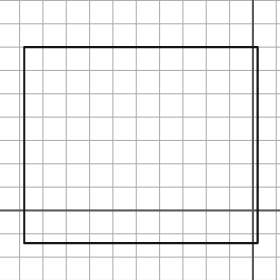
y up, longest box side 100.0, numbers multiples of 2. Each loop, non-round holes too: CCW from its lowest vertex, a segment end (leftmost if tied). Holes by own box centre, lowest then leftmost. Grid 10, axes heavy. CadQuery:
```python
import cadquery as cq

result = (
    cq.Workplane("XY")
    .moveTo(-98.0, -14.0)
    .lineTo(2.0, -14.0)
    .lineTo(2.0, 70.0)
    .lineTo(-98.0, 70.0)
    .close()
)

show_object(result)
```